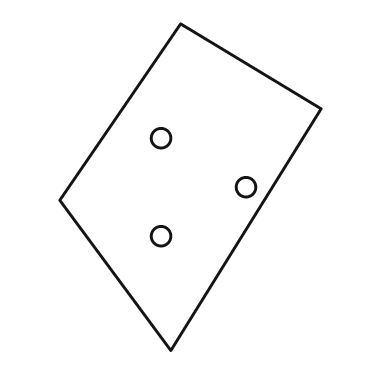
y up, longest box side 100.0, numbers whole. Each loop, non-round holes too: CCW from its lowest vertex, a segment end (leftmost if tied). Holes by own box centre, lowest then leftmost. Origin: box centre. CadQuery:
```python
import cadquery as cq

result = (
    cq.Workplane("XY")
    .moveTo(-6.0, -50.0)
    .lineTo(40.0, 24.0)
    .lineTo(-3.0, 50.0)
    .lineTo(-40.0, -4.0)
    .close()
    .moveTo(-9.0, -15.0)
    .circle(3.0)
    .moveTo(17.0, 0.0)
    .circle(3.0)
    .moveTo(-9.0, 15.0)
    .circle(3.0)
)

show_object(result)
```